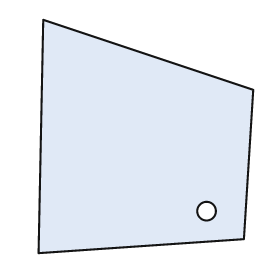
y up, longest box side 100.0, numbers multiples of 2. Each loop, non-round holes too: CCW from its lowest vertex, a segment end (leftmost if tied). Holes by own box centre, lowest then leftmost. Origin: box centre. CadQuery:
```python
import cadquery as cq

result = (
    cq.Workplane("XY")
    .moveTo(-46.0, -50.0)
    .lineTo(42.0, -44.0)
    .lineTo(46.0, 20.0)
    .lineTo(-44.0, 50.0)
    .close()
    .moveTo(26.0, -32.0)
    .circle(4.0)
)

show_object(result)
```